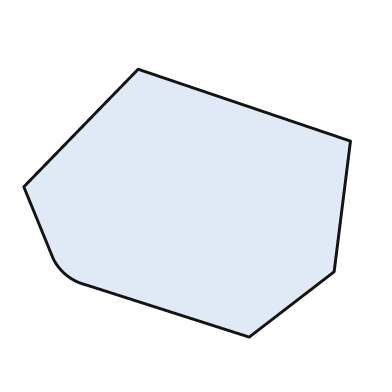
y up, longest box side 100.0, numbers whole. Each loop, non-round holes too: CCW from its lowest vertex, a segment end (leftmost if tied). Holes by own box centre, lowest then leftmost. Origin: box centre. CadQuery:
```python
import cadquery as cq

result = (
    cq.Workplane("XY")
    .moveTo(19.0, -41.0)
    .lineTo(45.0, -21.0)
    .lineTo(50.0, 19.0)
    .lineTo(-15.0, 41.0)
    .lineTo(-50.0, 5.0)
    .lineTo(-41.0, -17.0)
    .threePointArc((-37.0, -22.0), (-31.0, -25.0))
    .close()
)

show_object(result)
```